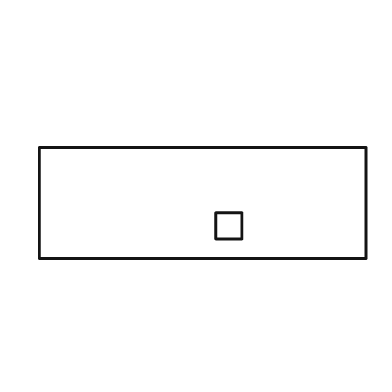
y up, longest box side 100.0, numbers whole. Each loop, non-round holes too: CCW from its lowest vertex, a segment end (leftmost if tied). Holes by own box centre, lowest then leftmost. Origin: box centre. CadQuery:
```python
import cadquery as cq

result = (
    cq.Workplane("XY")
    .moveTo(-50.0, -17.0)
    .lineTo(50.0, -17.0)
    .lineTo(50.0, 17.0)
    .lineTo(-50.0, 17.0)
    .close()
    .moveTo(4.0, -11.0)
    .lineTo(12.0, -11.0)
    .lineTo(12.0, -3.0)
    .lineTo(4.0, -3.0)
    .close()
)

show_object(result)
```